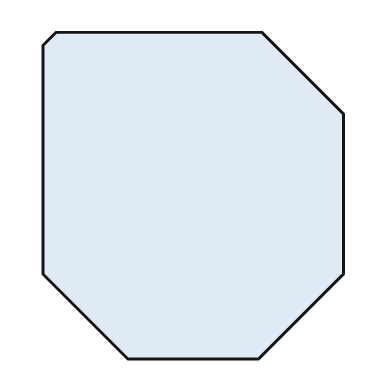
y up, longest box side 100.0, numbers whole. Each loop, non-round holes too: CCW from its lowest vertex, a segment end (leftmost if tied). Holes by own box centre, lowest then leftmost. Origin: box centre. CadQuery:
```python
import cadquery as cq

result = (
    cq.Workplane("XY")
    .moveTo(-20.0, -50.0)
    .lineTo(20.0, -50.0)
    .lineTo(46.0, -24.0)
    .lineTo(46.0, 25.0)
    .lineTo(21.0, 50.0)
    .lineTo(-42.0, 50.0)
    .lineTo(-46.0, 46.0)
    .lineTo(-46.0, -24.0)
    .close()
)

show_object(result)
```